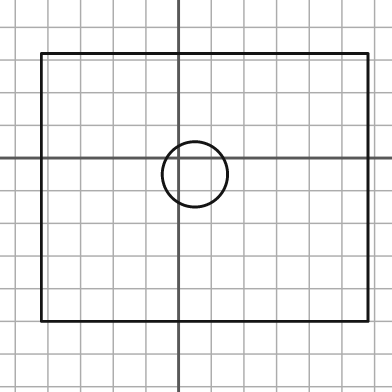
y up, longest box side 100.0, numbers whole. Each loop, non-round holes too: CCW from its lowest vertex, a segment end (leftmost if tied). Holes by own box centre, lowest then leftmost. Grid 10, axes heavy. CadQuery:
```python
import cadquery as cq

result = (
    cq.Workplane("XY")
    .moveTo(-42.0, -50.0)
    .lineTo(58.0, -50.0)
    .lineTo(58.0, 32.0)
    .lineTo(-42.0, 32.0)
    .close()
    .moveTo(5.0, -5.0)
    .circle(10.0)
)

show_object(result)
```